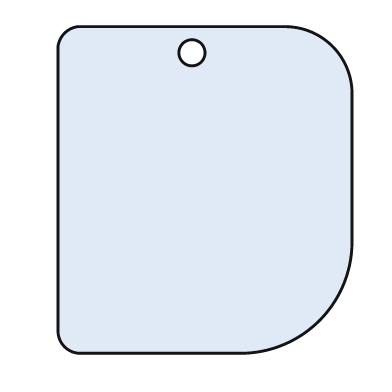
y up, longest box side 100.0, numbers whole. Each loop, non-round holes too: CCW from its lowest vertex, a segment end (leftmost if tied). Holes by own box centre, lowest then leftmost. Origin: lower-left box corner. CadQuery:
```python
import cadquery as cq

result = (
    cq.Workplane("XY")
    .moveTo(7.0, 0.0)
    .lineTo(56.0, 0.0)
    .threePointArc((80.0, 10.0), (90.0, 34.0))
    .lineTo(90.0, 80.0)
    .threePointArc((84.0, 94.0), (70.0, 100.0))
    .lineTo(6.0, 100.0)
    .threePointArc((2.0, 98.0), (0.0, 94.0))
    .lineTo(0.0, 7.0)
    .threePointArc((2.0, 2.0), (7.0, 0.0))
    .close()
    .moveTo(41.0, 92.0)
    .circle(4.0)
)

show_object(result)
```